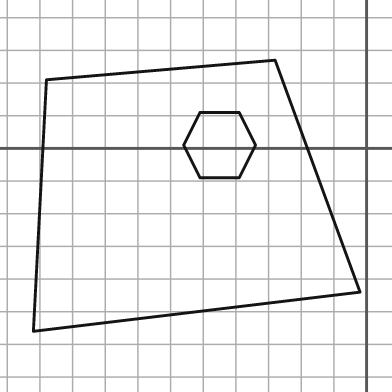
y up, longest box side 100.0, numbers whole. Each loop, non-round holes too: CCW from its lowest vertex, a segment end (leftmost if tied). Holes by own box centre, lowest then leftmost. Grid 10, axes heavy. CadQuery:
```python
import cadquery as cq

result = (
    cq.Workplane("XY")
    .moveTo(-102.0, -56.0)
    .lineTo(-2.0, -44.0)
    .lineTo(-28.0, 27.0)
    .lineTo(-98.0, 21.0)
    .close()
    .moveTo(-51.0, -9.0)
    .lineTo(-39.0, -9.0)
    .lineTo(-34.0, 1.0)
    .lineTo(-39.0, 11.0)
    .lineTo(-51.0, 11.0)
    .lineTo(-56.0, 1.0)
    .close()
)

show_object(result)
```